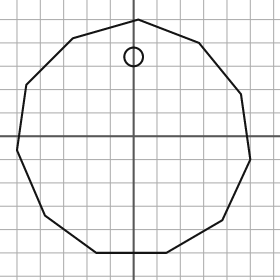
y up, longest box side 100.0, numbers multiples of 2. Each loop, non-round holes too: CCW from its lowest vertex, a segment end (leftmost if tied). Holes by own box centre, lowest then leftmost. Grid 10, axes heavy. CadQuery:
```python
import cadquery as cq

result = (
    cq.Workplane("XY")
    .moveTo(-16.0, -50.0)
    .lineTo(14.0, -50.0)
    .lineTo(38.0, -36.0)
    .lineTo(50.0, -10.0)
    .lineTo(46.0, 18.0)
    .lineTo(28.0, 40.0)
    .lineTo(2.0, 50.0)
    .lineTo(-26.0, 42.0)
    .lineTo(-46.0, 22.0)
    .lineTo(-50.0, -6.0)
    .lineTo(-38.0, -34.0)
    .close()
    .moveTo(0.0, 34.0)
    .circle(4.0)
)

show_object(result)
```